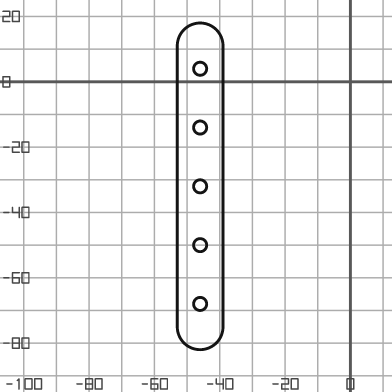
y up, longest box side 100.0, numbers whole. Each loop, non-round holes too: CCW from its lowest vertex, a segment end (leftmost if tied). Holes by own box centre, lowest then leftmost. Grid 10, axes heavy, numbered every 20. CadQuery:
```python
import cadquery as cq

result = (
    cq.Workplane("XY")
    .moveTo(-53.0, -75.0)
    .threePointArc((-46.0, -82.0), (-39.0, -75.0))
    .lineTo(-39.0, 11.0)
    .threePointArc((-46.0, 18.0), (-53.0, 11.0))
    .close()
    .moveTo(-46.0, -68.0)
    .circle(2.0)
    .moveTo(-46.0, -50.0)
    .circle(2.0)
    .moveTo(-46.0, -32.0)
    .circle(2.0)
    .moveTo(-46.0, -14.0)
    .circle(2.0)
    .moveTo(-46.0, 4.0)
    .circle(2.0)
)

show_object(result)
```